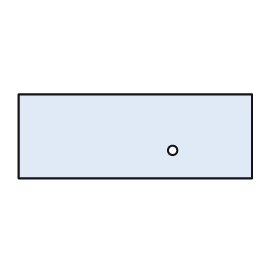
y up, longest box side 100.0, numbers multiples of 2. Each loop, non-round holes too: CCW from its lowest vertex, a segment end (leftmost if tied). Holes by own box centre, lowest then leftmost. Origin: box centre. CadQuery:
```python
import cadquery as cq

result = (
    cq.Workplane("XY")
    .moveTo(-50.0, -18.0)
    .lineTo(50.0, -18.0)
    .lineTo(50.0, 18.0)
    .lineTo(-50.0, 18.0)
    .close()
    .moveTo(16.0, -6.0)
    .circle(2.0)
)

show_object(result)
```